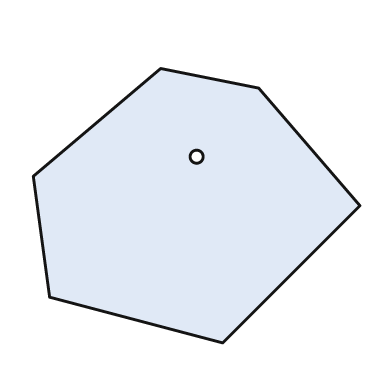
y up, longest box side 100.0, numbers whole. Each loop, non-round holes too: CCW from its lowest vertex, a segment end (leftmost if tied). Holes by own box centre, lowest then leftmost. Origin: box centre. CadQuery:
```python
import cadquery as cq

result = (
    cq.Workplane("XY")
    .moveTo(8.0, -42.0)
    .lineTo(50.0, 0.0)
    .lineTo(19.0, 36.0)
    .lineTo(-11.0, 42.0)
    .lineTo(-50.0, 9.0)
    .lineTo(-45.0, -28.0)
    .close()
    .moveTo(0.0, 15.0)
    .circle(2.0)
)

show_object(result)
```